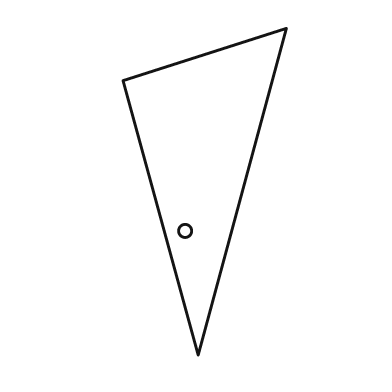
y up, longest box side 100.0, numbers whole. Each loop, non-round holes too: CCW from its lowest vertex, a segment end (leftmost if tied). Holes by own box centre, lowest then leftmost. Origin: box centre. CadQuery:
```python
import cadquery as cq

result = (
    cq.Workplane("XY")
    .moveTo(-2.0, -50.0)
    .lineTo(25.0, 50.0)
    .lineTo(-25.0, 34.0)
    .close()
    .moveTo(-6.0, -12.0)
    .circle(2.0)
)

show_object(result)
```